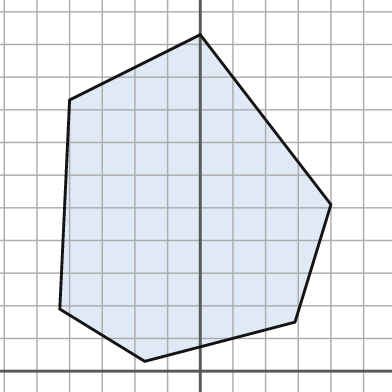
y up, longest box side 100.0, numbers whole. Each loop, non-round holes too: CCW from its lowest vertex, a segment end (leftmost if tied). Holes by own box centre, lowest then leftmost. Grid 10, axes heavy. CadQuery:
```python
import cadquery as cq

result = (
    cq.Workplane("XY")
    .moveTo(-17.0, 3.0)
    .lineTo(29.0, 15.0)
    .lineTo(40.0, 51.0)
    .lineTo(0.0, 103.0)
    .lineTo(-40.0, 83.0)
    .lineTo(-43.0, 19.0)
    .close()
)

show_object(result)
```